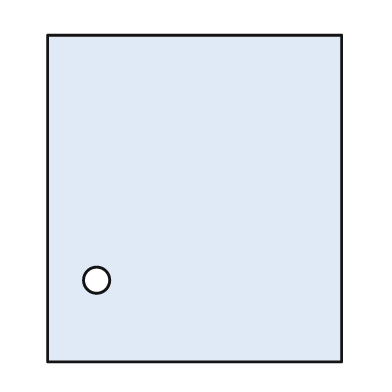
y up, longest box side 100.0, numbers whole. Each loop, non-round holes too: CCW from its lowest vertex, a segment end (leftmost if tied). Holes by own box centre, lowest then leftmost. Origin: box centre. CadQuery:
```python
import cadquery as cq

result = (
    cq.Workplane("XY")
    .moveTo(-45.0, -50.0)
    .lineTo(45.0, -50.0)
    .lineTo(45.0, 50.0)
    .lineTo(-45.0, 50.0)
    .close()
    .moveTo(-30.0, -25.0)
    .circle(4.0)
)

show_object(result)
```